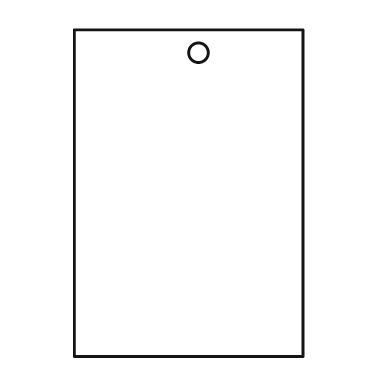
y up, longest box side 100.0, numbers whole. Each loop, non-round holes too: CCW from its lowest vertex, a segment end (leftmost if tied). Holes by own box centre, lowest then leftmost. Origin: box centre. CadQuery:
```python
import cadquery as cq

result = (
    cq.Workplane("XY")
    .moveTo(-35.0, -50.0)
    .lineTo(35.0, -50.0)
    .lineTo(35.0, 50.0)
    .lineTo(-35.0, 50.0)
    .close()
    .moveTo(3.0, 43.0)
    .circle(3.0)
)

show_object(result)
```